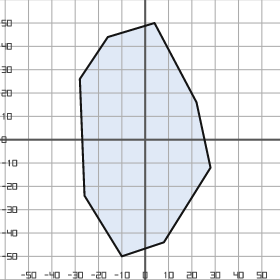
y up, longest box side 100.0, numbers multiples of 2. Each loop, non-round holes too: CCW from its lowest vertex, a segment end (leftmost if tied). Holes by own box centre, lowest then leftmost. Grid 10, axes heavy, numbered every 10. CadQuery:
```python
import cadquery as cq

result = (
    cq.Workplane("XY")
    .moveTo(-10.0, -50.0)
    .lineTo(8.0, -44.0)
    .lineTo(28.0, -12.0)
    .lineTo(22.0, 16.0)
    .lineTo(4.0, 50.0)
    .lineTo(-16.0, 44.0)
    .lineTo(-28.0, 26.0)
    .lineTo(-26.0, -24.0)
    .close()
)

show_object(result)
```